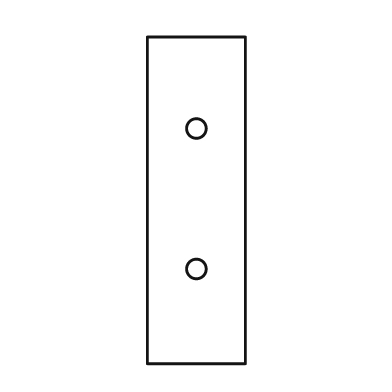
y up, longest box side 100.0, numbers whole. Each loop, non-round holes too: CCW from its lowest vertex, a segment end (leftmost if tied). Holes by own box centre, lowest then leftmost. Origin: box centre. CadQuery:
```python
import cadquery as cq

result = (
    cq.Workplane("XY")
    .moveTo(-15.0, -50.0)
    .lineTo(15.0, -50.0)
    .lineTo(15.0, 50.0)
    .lineTo(-15.0, 50.0)
    .close()
    .moveTo(0.0, -21.0)
    .circle(3.0)
    .moveTo(0.0, 22.0)
    .circle(3.0)
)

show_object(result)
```